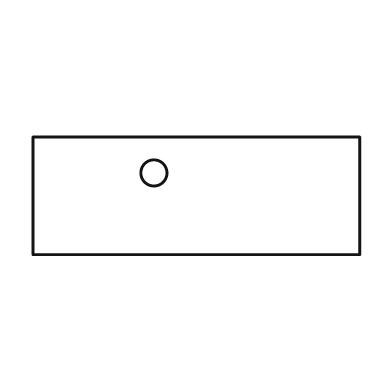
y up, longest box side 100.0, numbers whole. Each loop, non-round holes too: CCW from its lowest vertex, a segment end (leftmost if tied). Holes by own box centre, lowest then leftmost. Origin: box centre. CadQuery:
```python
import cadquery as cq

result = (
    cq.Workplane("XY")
    .moveTo(-50.0, -18.0)
    .lineTo(50.0, -18.0)
    .lineTo(50.0, 18.0)
    .lineTo(-50.0, 18.0)
    .close()
    .moveTo(-13.0, 7.0)
    .circle(4.0)
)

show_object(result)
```